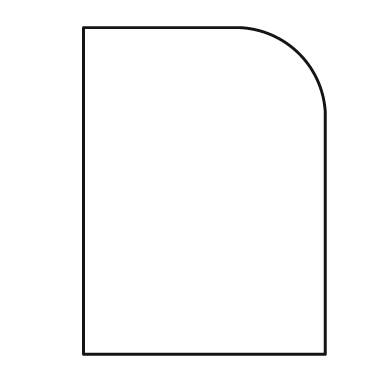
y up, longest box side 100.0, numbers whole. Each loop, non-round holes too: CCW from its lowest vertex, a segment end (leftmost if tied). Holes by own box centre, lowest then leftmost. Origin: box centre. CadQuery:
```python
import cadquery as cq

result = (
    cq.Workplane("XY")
    .moveTo(-37.0, -50.0)
    .lineTo(37.0, -50.0)
    .lineTo(37.0, 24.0)
    .threePointArc((29.0, 42.0), (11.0, 50.0))
    .lineTo(-37.0, 50.0)
    .close()
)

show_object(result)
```